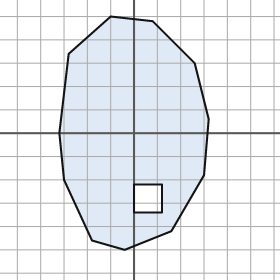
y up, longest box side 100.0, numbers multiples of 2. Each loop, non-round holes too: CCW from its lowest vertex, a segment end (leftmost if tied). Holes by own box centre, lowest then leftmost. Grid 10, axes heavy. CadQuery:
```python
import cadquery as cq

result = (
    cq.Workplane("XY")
    .moveTo(-4.0, -50.0)
    .lineTo(16.0, -42.0)
    .lineTo(30.0, -18.0)
    .lineTo(32.0, 6.0)
    .lineTo(26.0, 30.0)
    .lineTo(8.0, 48.0)
    .lineTo(-10.0, 50.0)
    .lineTo(-28.0, 34.0)
    .lineTo(-32.0, 0.0)
    .lineTo(-30.0, -20.0)
    .lineTo(-18.0, -46.0)
    .close()
    .moveTo(0.0, -34.0)
    .lineTo(12.0, -34.0)
    .lineTo(12.0, -22.0)
    .lineTo(0.0, -22.0)
    .close()
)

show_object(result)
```